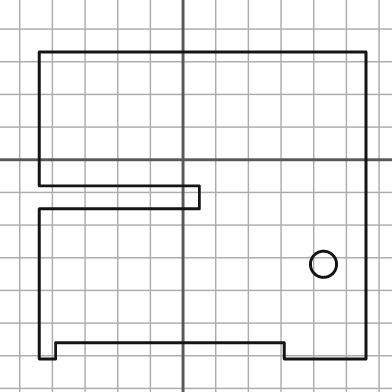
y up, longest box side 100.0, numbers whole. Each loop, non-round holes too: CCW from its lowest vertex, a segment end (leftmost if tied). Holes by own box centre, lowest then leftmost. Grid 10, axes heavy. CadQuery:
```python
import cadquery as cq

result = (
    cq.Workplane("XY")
    .moveTo(-44.0, -61.0)
    .lineTo(-39.0, -61.0)
    .lineTo(-39.0, -56.0)
    .lineTo(31.0, -56.0)
    .lineTo(31.0, -61.0)
    .lineTo(56.0, -61.0)
    .lineTo(56.0, 33.0)
    .lineTo(-44.0, 33.0)
    .lineTo(-44.0, -8.0)
    .lineTo(5.0, -8.0)
    .lineTo(5.0, -15.0)
    .lineTo(-44.0, -15.0)
    .close()
    .moveTo(43.0, -32.0)
    .circle(4.0)
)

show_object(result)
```